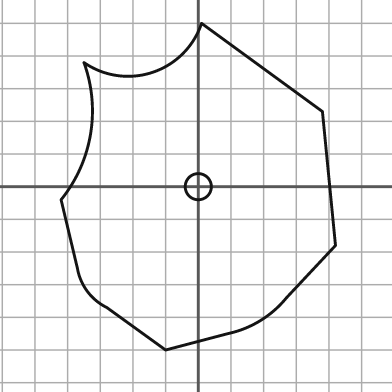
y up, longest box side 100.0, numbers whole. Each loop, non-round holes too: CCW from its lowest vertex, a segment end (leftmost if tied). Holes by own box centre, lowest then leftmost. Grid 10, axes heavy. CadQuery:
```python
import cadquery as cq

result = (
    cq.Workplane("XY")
    .moveTo(-10.0, -50.0)
    .lineTo(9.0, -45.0)
    .threePointArc((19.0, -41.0), (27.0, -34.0))
    .lineTo(42.0, -18.0)
    .lineTo(38.0, 23.0)
    .lineTo(1.0, 50.0)
    .threePointArc((-14.0, 35.0), (-35.0, 38.0))
    .threePointArc((-33.0, 16.0), (-42.0, -4.0))
    .lineTo(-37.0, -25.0)
    .threePointArc((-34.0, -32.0), (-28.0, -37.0))
    .close()
    .moveTo(0.0, 0.0)
    .circle(4.0)
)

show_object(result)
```